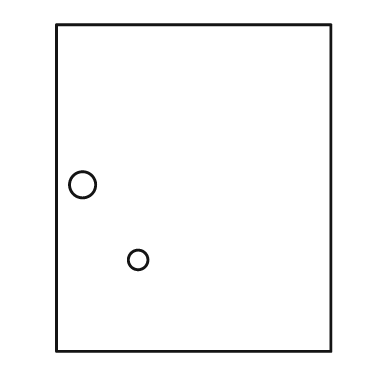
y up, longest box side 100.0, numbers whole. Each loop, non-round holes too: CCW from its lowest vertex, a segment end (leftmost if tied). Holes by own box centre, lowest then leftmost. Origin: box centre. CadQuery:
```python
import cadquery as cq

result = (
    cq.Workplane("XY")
    .moveTo(-42.0, -50.0)
    .lineTo(42.0, -50.0)
    .lineTo(42.0, 50.0)
    .lineTo(-42.0, 50.0)
    .close()
    .moveTo(-17.0, -22.0)
    .circle(3.0)
    .moveTo(-34.0, 1.0)
    .circle(4.0)
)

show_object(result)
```